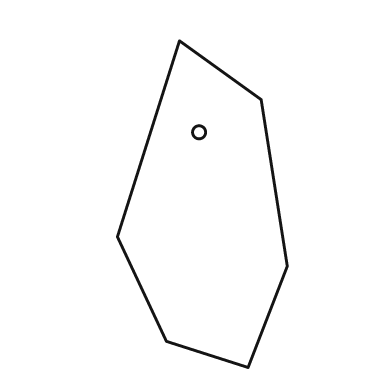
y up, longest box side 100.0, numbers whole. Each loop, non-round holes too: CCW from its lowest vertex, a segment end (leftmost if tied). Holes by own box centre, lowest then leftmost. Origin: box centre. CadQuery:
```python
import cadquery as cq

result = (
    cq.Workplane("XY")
    .moveTo(14.0, -50.0)
    .lineTo(26.0, -19.0)
    .lineTo(18.0, 32.0)
    .lineTo(-7.0, 50.0)
    .lineTo(-26.0, -10.0)
    .lineTo(-11.0, -42.0)
    .close()
    .moveTo(-1.0, 22.0)
    .circle(2.0)
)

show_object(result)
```